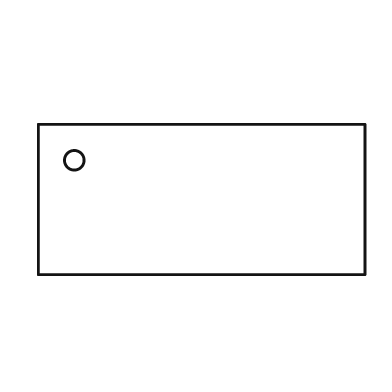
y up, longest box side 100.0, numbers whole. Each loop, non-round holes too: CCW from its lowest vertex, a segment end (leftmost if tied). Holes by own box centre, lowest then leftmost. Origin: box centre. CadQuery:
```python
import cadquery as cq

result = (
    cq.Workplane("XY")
    .moveTo(-50.0, -23.0)
    .lineTo(50.0, -23.0)
    .lineTo(50.0, 23.0)
    .lineTo(-50.0, 23.0)
    .close()
    .moveTo(-39.0, 12.0)
    .circle(3.0)
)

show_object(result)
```